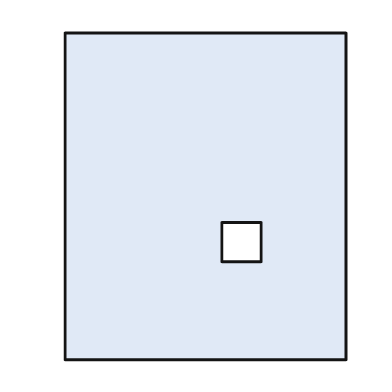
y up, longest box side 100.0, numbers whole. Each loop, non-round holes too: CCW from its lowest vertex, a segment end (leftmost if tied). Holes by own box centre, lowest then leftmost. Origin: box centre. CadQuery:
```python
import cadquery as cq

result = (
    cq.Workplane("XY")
    .moveTo(-43.0, -50.0)
    .lineTo(43.0, -50.0)
    .lineTo(43.0, 50.0)
    .lineTo(-43.0, 50.0)
    .close()
    .moveTo(5.0, -20.0)
    .lineTo(17.0, -20.0)
    .lineTo(17.0, -8.0)
    .lineTo(5.0, -8.0)
    .close()
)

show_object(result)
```